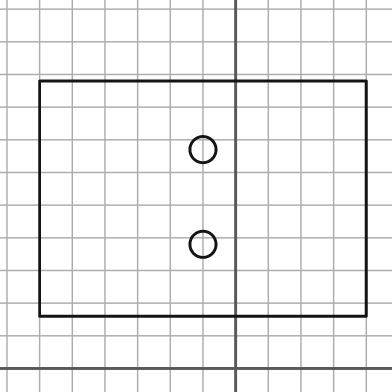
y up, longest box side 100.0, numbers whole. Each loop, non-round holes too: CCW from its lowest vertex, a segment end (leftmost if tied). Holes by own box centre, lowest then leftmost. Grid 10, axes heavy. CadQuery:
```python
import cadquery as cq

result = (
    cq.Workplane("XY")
    .moveTo(-60.0, 16.0)
    .lineTo(40.0, 16.0)
    .lineTo(40.0, 88.0)
    .lineTo(-60.0, 88.0)
    .close()
    .moveTo(-10.0, 38.0)
    .circle(4.0)
    .moveTo(-10.0, 67.0)
    .circle(4.0)
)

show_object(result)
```